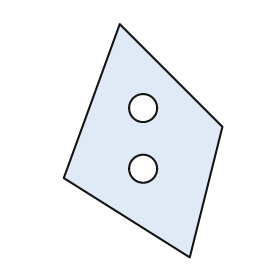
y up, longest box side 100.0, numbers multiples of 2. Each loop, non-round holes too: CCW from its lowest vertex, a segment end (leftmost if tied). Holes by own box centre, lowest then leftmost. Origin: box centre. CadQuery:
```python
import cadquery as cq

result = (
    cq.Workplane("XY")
    .moveTo(20.0, -50.0)
    .lineTo(34.0, 6.0)
    .lineTo(-10.0, 50.0)
    .lineTo(-34.0, -16.0)
    .close()
    .moveTo(0.0, -12.0)
    .circle(6.0)
    .moveTo(0.0, 14.0)
    .circle(6.0)
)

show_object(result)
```